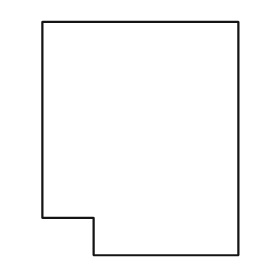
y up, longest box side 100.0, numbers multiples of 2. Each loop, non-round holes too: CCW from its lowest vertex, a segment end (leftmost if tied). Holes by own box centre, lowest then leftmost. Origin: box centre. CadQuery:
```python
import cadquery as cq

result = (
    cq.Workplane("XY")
    .moveTo(-20.0, -50.0)
    .lineTo(42.0, -50.0)
    .lineTo(42.0, 50.0)
    .lineTo(-42.0, 50.0)
    .lineTo(-42.0, -34.0)
    .lineTo(-20.0, -34.0)
    .close()
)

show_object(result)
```